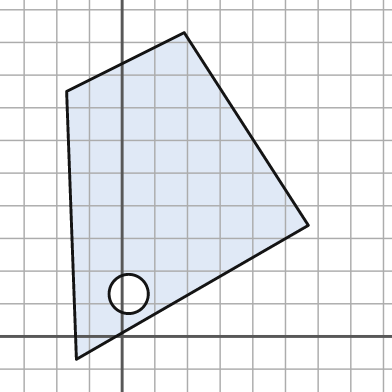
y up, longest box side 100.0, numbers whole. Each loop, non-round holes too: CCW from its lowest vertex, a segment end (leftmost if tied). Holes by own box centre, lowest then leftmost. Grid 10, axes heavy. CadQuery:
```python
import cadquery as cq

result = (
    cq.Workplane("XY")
    .moveTo(-14.0, -7.0)
    .lineTo(57.0, 34.0)
    .lineTo(19.0, 93.0)
    .lineTo(-17.0, 75.0)
    .close()
    .moveTo(2.0, 13.0)
    .circle(6.0)
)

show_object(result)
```